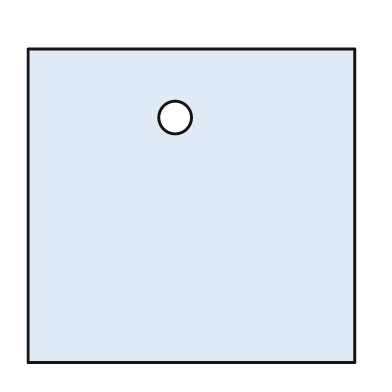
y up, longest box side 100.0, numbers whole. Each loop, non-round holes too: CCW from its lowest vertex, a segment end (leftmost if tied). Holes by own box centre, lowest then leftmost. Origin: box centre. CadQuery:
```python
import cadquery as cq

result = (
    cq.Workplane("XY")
    .moveTo(-50.0, -48.0)
    .lineTo(50.0, -48.0)
    .lineTo(50.0, 48.0)
    .lineTo(-50.0, 48.0)
    .close()
    .moveTo(-5.0, 27.0)
    .circle(5.0)
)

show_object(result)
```